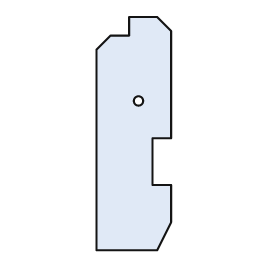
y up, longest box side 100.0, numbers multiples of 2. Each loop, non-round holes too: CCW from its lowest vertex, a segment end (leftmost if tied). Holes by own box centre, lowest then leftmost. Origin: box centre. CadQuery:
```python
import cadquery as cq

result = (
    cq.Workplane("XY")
    .moveTo(-16.0, -50.0)
    .lineTo(10.0, -50.0)
    .lineTo(16.0, -38.0)
    .lineTo(16.0, -22.0)
    .lineTo(8.0, -22.0)
    .lineTo(8.0, -2.0)
    .lineTo(16.0, -2.0)
    .lineTo(16.0, 44.0)
    .lineTo(10.0, 50.0)
    .lineTo(-2.0, 50.0)
    .lineTo(-2.0, 42.0)
    .lineTo(-10.0, 42.0)
    .lineTo(-16.0, 36.0)
    .close()
    .moveTo(2.0, 14.0)
    .circle(2.0)
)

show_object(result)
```